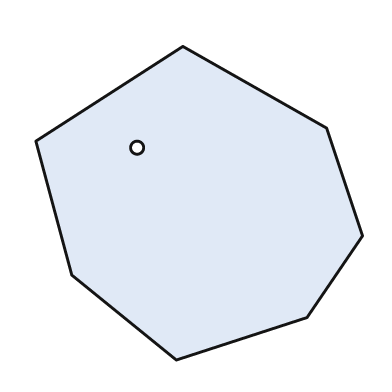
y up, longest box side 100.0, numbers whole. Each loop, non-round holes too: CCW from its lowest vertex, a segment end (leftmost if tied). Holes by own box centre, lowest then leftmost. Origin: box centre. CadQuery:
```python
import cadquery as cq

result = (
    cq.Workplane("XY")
    .moveTo(-7.0, -48.0)
    .lineTo(33.0, -35.0)
    .lineTo(50.0, -10.0)
    .lineTo(39.0, 23.0)
    .lineTo(-5.0, 48.0)
    .lineTo(-50.0, 19.0)
    .lineTo(-39.0, -22.0)
    .close()
    .moveTo(-19.0, 17.0)
    .circle(2.0)
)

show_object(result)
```